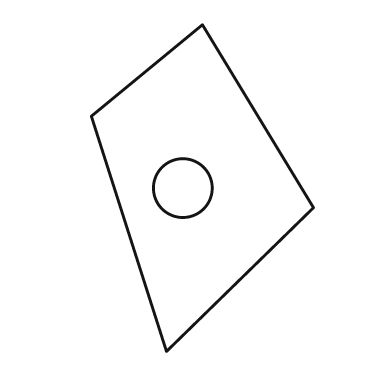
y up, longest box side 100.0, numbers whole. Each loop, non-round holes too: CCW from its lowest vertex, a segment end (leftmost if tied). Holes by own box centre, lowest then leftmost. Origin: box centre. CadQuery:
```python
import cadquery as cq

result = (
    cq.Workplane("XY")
    .moveTo(-11.0, -50.0)
    .lineTo(34.0, -6.0)
    .lineTo(0.0, 50.0)
    .lineTo(-34.0, 22.0)
    .close()
    .moveTo(-6.0, 0.0)
    .circle(9.0)
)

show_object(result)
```